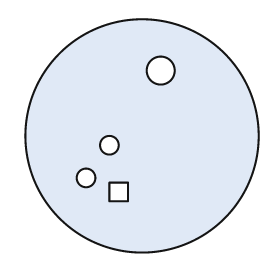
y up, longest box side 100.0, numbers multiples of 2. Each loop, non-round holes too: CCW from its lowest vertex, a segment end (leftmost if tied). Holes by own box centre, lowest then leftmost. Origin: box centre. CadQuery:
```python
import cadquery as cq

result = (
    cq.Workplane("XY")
    .moveTo(0.0, 0.0)
    .circle(50.0)
    .moveTo(-14.0, -28.0)
    .lineTo(-6.0, -28.0)
    .lineTo(-6.0, -20.0)
    .lineTo(-14.0, -20.0)
    .close()
    .moveTo(-24.0, -18.0)
    .circle(4.0)
    .moveTo(-14.0, -4.0)
    .circle(4.0)
    .moveTo(8.0, 28.0)
    .circle(6.0)
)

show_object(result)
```